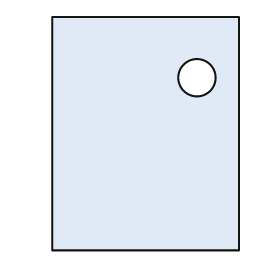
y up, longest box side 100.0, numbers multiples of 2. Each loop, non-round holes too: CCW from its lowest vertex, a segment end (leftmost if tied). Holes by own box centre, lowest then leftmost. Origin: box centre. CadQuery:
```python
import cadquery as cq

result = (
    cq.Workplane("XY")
    .moveTo(-40.0, -50.0)
    .lineTo(40.0, -50.0)
    .lineTo(40.0, 50.0)
    .lineTo(-40.0, 50.0)
    .close()
    .moveTo(22.0, 24.0)
    .circle(8.0)
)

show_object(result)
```